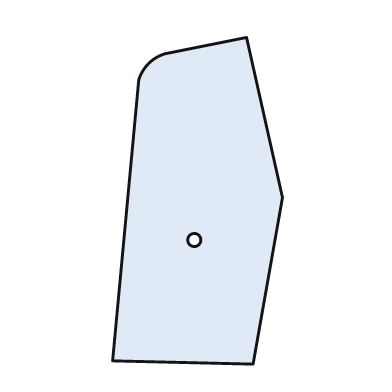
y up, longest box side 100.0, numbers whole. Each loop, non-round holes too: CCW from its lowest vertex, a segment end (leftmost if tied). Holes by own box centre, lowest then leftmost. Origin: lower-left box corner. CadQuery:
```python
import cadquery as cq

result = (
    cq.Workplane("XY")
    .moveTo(43.0, 0.0)
    .lineTo(52.0, 51.0)
    .lineTo(41.0, 100.0)
    .lineTo(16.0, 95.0)
    .threePointArc((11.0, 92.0), (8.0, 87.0))
    .lineTo(0.0, 1.0)
    .close()
    .moveTo(25.0, 38.0)
    .circle(2.0)
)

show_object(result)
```